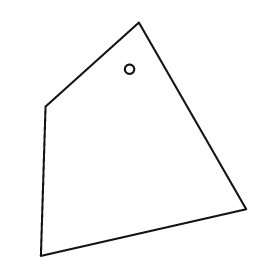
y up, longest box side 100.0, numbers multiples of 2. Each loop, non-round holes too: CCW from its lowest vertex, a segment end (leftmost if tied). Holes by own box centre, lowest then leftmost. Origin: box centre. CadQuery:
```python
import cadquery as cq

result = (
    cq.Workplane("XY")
    .moveTo(-44.0, -50.0)
    .lineTo(44.0, -30.0)
    .lineTo(-2.0, 50.0)
    .lineTo(-42.0, 14.0)
    .close()
    .moveTo(-6.0, 30.0)
    .circle(2.0)
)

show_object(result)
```